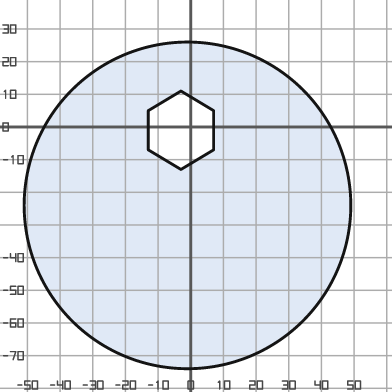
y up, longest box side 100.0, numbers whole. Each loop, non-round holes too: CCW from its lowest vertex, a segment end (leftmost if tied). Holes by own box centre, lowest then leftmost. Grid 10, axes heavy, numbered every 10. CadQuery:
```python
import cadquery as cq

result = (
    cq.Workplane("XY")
    .moveTo(-1.0, -24.0)
    .circle(50.0)
    .moveTo(-3.0, -13.0)
    .lineTo(7.0, -7.0)
    .lineTo(7.0, 5.0)
    .lineTo(-3.0, 11.0)
    .lineTo(-13.0, 5.0)
    .lineTo(-13.0, -7.0)
    .close()
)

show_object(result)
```